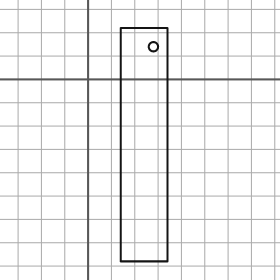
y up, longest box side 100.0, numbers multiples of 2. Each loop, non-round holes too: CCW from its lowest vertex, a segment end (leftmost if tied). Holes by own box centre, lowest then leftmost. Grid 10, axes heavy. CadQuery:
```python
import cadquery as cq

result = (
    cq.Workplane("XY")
    .moveTo(14.0, -78.0)
    .lineTo(34.0, -78.0)
    .lineTo(34.0, 22.0)
    .lineTo(14.0, 22.0)
    .close()
    .moveTo(28.0, 14.0)
    .circle(2.0)
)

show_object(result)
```